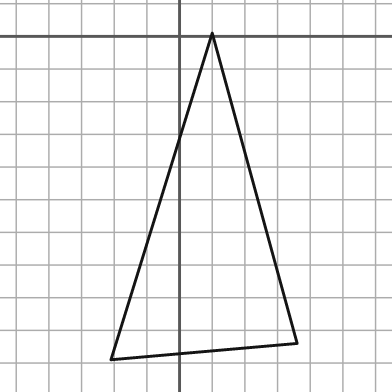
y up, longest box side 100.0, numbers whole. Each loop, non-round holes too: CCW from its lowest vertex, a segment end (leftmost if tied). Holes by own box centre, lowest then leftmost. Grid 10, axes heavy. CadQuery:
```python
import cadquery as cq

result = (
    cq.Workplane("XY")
    .moveTo(-21.0, -99.0)
    .lineTo(36.0, -94.0)
    .lineTo(10.0, 1.0)
    .close()
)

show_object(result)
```